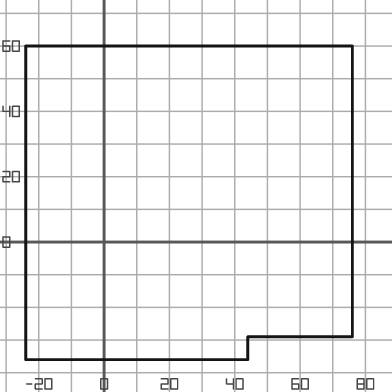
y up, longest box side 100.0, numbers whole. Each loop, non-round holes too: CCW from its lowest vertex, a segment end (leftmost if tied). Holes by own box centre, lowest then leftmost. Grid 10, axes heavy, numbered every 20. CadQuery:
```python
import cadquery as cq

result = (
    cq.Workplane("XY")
    .moveTo(-24.0, -36.0)
    .lineTo(44.0, -36.0)
    .lineTo(44.0, -29.0)
    .lineTo(76.0, -29.0)
    .lineTo(76.0, 60.0)
    .lineTo(-24.0, 60.0)
    .close()
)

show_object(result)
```